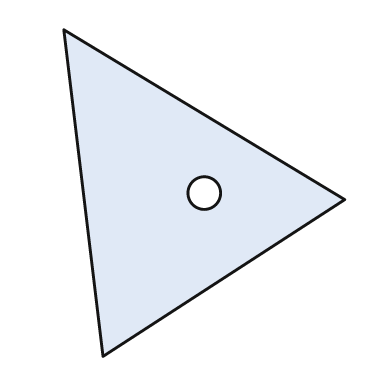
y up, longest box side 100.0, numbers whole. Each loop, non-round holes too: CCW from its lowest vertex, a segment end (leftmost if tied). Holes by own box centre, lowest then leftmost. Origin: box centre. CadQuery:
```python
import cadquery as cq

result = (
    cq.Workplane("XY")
    .moveTo(-31.0, -50.0)
    .lineTo(43.0, -2.0)
    .lineTo(-43.0, 50.0)
    .close()
    .moveTo(0.0, 0.0)
    .circle(5.0)
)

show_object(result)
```